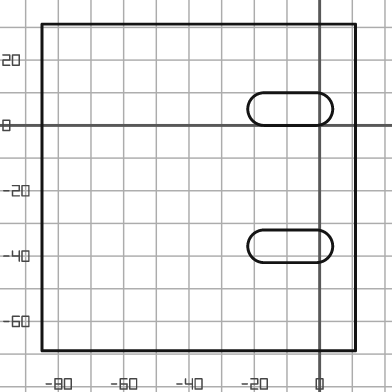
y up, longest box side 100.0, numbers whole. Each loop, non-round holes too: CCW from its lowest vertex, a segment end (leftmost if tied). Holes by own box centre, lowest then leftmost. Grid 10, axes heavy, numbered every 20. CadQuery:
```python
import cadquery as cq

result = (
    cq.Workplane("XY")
    .moveTo(-85.0, -69.0)
    .lineTo(11.0, -69.0)
    .lineTo(11.0, 31.0)
    .lineTo(-85.0, 31.0)
    .close()
    .moveTo(-17.0, -42.0)
    .lineTo(-1.0, -42.0)
    .threePointArc((4.0, -37.0), (-1.0, -32.0))
    .lineTo(-17.0, -32.0)
    .threePointArc((-22.0, -37.0), (-17.0, -42.0))
    .close()
    .moveTo(-17.0, 0.0)
    .lineTo(-1.0, 0.0)
    .threePointArc((4.0, 5.0), (-1.0, 10.0))
    .lineTo(-17.0, 10.0)
    .threePointArc((-22.0, 5.0), (-17.0, 0.0))
    .close()
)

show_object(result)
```